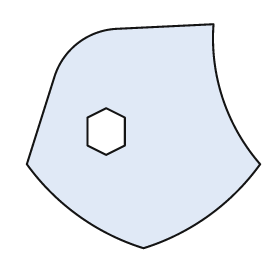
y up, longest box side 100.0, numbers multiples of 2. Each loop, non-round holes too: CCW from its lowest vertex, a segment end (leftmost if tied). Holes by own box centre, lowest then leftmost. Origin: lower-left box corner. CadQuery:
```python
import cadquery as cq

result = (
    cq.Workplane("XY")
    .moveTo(50.0, 0.0)
    .threePointArc((78.0, 14.0), (100.0, 36.0))
    .threePointArc((84.0, 64.0), (80.0, 96.0))
    .lineTo(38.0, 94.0)
    .threePointArc((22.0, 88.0), (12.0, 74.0))
    .lineTo(0.0, 36.0)
    .threePointArc((22.0, 14.0), (50.0, 0.0))
    .close()
    .moveTo(34.0, 40.0)
    .lineTo(42.0, 44.0)
    .lineTo(42.0, 56.0)
    .lineTo(34.0, 60.0)
    .lineTo(26.0, 56.0)
    .lineTo(26.0, 44.0)
    .close()
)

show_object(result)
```